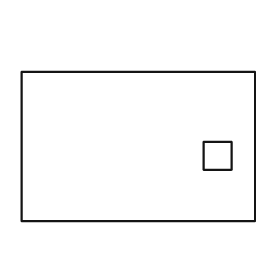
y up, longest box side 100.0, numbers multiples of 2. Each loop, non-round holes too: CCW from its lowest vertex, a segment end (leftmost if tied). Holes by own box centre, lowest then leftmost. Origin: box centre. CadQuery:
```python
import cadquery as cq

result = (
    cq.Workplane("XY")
    .moveTo(-50.0, -32.0)
    .lineTo(50.0, -32.0)
    .lineTo(50.0, 32.0)
    .lineTo(-50.0, 32.0)
    .close()
    .moveTo(28.0, -10.0)
    .lineTo(40.0, -10.0)
    .lineTo(40.0, 2.0)
    .lineTo(28.0, 2.0)
    .close()
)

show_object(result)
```